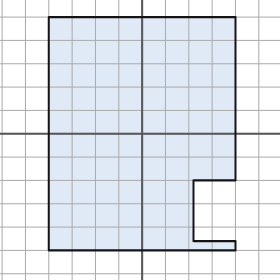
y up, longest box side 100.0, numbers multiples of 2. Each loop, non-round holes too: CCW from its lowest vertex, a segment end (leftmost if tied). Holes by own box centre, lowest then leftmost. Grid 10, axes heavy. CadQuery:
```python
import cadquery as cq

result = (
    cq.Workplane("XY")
    .moveTo(-40.0, -50.0)
    .lineTo(40.0, -50.0)
    .lineTo(40.0, -46.0)
    .lineTo(22.0, -46.0)
    .lineTo(22.0, -20.0)
    .lineTo(40.0, -20.0)
    .lineTo(40.0, 50.0)
    .lineTo(-40.0, 50.0)
    .close()
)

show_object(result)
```